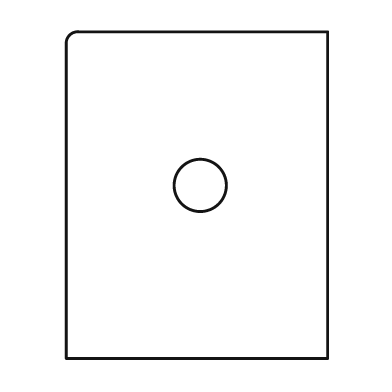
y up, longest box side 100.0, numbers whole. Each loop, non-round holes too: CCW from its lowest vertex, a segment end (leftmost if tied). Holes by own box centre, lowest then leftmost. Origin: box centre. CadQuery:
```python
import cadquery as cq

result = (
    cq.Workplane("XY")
    .moveTo(-40.0, -50.0)
    .lineTo(40.0, -50.0)
    .lineTo(40.0, 50.0)
    .lineTo(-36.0, 50.0)
    .threePointArc((-39.0, 49.0), (-40.0, 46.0))
    .close()
    .moveTo(1.0, 3.0)
    .circle(8.0)
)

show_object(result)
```